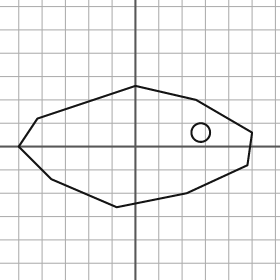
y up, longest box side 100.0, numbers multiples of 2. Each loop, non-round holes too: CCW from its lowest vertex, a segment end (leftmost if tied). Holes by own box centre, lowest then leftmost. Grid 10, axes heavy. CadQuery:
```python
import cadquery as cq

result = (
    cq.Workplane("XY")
    .moveTo(-8.0, -26.0)
    .lineTo(22.0, -20.0)
    .lineTo(48.0, -8.0)
    .lineTo(50.0, 6.0)
    .lineTo(26.0, 20.0)
    .lineTo(0.0, 26.0)
    .lineTo(-42.0, 12.0)
    .lineTo(-50.0, 0.0)
    .lineTo(-36.0, -14.0)
    .close()
    .moveTo(28.0, 6.0)
    .circle(4.0)
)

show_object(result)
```